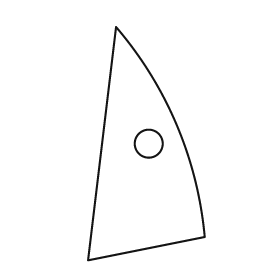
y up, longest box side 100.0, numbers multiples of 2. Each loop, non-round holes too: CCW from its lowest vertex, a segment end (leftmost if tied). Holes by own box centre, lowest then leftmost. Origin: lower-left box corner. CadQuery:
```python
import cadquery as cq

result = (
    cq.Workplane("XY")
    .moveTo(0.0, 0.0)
    .lineTo(50.0, 10.0)
    .threePointArc((38.0, 58.0), (12.0, 100.0))
    .close()
    .moveTo(26.0, 50.0)
    .circle(6.0)
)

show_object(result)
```